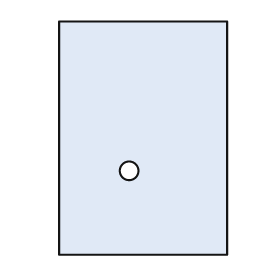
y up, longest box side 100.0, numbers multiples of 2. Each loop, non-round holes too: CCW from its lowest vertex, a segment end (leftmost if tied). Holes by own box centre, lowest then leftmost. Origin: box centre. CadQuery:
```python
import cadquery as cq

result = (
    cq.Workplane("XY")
    .moveTo(-36.0, -50.0)
    .lineTo(36.0, -50.0)
    .lineTo(36.0, 50.0)
    .lineTo(-36.0, 50.0)
    .close()
    .moveTo(-6.0, -14.0)
    .circle(4.0)
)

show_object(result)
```